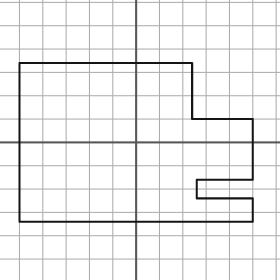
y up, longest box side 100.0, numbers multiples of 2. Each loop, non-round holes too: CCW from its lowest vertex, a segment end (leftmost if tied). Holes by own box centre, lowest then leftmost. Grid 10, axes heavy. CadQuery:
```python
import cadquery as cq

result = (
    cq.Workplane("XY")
    .moveTo(-50.0, -34.0)
    .lineTo(50.0, -34.0)
    .lineTo(50.0, -24.0)
    .lineTo(26.0, -24.0)
    .lineTo(26.0, -16.0)
    .lineTo(50.0, -16.0)
    .lineTo(50.0, 10.0)
    .lineTo(24.0, 10.0)
    .lineTo(24.0, 34.0)
    .lineTo(-50.0, 34.0)
    .close()
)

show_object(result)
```